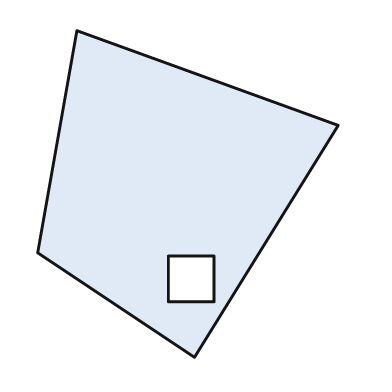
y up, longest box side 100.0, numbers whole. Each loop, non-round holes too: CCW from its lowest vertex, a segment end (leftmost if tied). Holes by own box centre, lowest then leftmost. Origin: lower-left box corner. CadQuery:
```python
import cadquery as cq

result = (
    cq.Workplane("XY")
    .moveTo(48.0, 0.0)
    .lineTo(92.0, 71.0)
    .lineTo(12.0, 100.0)
    .lineTo(0.0, 32.0)
    .close()
    .moveTo(40.0, 17.0)
    .lineTo(54.0, 17.0)
    .lineTo(54.0, 31.0)
    .lineTo(40.0, 31.0)
    .close()
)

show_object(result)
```